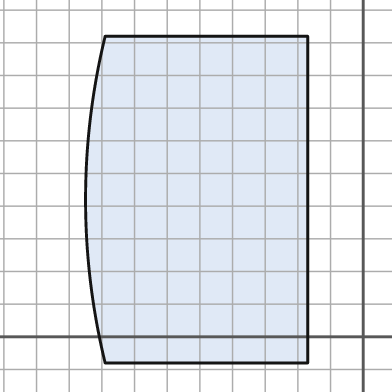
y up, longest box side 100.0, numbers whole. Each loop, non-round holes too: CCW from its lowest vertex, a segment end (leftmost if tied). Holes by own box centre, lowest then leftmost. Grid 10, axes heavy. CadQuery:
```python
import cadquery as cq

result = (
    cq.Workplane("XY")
    .moveTo(-79.0, -8.0)
    .lineTo(-17.0, -8.0)
    .lineTo(-17.0, 92.0)
    .lineTo(-79.0, 92.0)
    .threePointArc((-85.0, 42.0), (-79.0, -8.0))
    .close()
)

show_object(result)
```